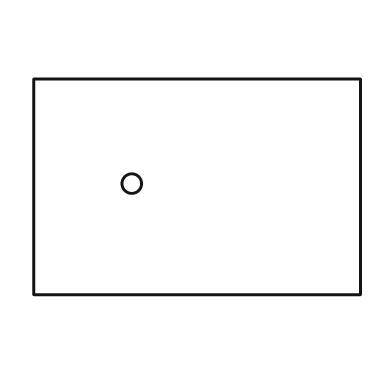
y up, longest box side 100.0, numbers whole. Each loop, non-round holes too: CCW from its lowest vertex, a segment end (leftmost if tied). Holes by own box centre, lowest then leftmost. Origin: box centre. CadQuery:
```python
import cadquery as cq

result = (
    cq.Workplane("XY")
    .moveTo(-50.0, -33.0)
    .lineTo(50.0, -33.0)
    .lineTo(50.0, 33.0)
    .lineTo(-50.0, 33.0)
    .close()
    .moveTo(-20.0, 1.0)
    .circle(3.0)
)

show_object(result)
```